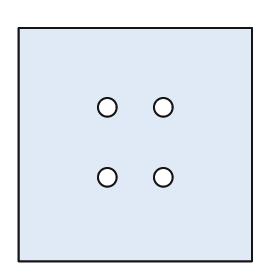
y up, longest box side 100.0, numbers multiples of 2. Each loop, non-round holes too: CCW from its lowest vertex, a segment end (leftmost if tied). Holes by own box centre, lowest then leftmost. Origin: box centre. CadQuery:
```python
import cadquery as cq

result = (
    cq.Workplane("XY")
    .moveTo(-50.0, -50.0)
    .lineTo(50.0, -50.0)
    .lineTo(50.0, 50.0)
    .lineTo(-50.0, 50.0)
    .close()
    .moveTo(-12.0, -14.0)
    .circle(4.0)
    .moveTo(12.0, -14.0)
    .circle(4.0)
    .moveTo(-12.0, 16.0)
    .circle(4.0)
    .moveTo(12.0, 16.0)
    .circle(4.0)
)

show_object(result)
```